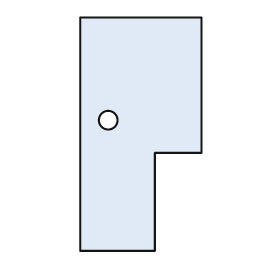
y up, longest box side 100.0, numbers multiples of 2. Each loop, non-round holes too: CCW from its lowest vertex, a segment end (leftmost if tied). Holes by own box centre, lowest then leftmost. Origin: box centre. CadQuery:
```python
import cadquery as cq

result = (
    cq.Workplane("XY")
    .moveTo(-26.0, -50.0)
    .lineTo(6.0, -50.0)
    .lineTo(6.0, -8.0)
    .lineTo(26.0, -8.0)
    .lineTo(26.0, 50.0)
    .lineTo(-26.0, 50.0)
    .close()
    .moveTo(-14.0, 6.0)
    .circle(4.0)
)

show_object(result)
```